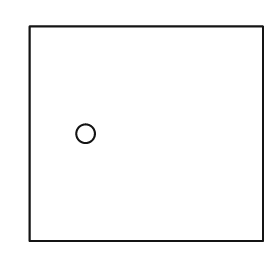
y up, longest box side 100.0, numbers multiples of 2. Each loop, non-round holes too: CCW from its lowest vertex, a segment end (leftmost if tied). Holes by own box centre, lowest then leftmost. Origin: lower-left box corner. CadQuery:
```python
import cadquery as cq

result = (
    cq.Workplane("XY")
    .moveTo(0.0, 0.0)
    .lineTo(100.0, 0.0)
    .lineTo(100.0, 92.0)
    .lineTo(0.0, 92.0)
    .close()
    .moveTo(24.0, 46.0)
    .circle(4.0)
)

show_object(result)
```